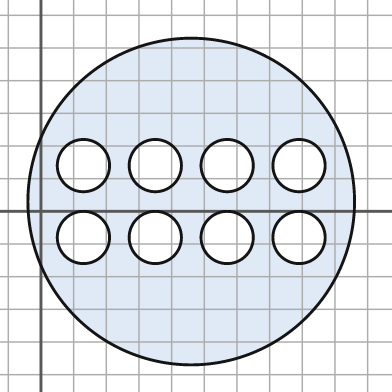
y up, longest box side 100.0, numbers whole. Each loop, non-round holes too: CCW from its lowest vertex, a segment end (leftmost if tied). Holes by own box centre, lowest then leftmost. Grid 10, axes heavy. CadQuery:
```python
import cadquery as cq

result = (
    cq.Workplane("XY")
    .moveTo(46.0, 3.0)
    .circle(50.0)
    .moveTo(13.0, -8.0)
    .circle(8.0)
    .moveTo(35.0, -8.0)
    .circle(8.0)
    .moveTo(57.0, -8.0)
    .circle(8.0)
    .moveTo(79.0, -8.0)
    .circle(8.0)
    .moveTo(13.0, 14.0)
    .circle(8.0)
    .moveTo(35.0, 14.0)
    .circle(8.0)
    .moveTo(57.0, 14.0)
    .circle(8.0)
    .moveTo(79.0, 14.0)
    .circle(8.0)
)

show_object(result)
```